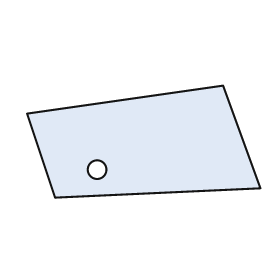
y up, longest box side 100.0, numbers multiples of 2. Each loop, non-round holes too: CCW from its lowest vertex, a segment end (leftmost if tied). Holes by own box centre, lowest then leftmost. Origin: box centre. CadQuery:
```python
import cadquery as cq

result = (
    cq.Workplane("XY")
    .moveTo(-38.0, -24.0)
    .lineTo(50.0, -20.0)
    .lineTo(34.0, 24.0)
    .lineTo(-50.0, 12.0)
    .close()
    .moveTo(-20.0, -12.0)
    .circle(4.0)
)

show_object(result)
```